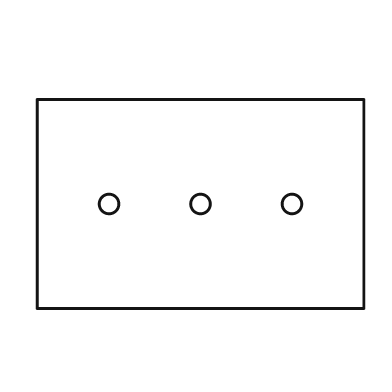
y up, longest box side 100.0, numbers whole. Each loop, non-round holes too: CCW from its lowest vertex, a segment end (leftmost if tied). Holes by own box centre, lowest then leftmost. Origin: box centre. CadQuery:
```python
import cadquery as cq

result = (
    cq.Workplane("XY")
    .moveTo(-50.0, -32.0)
    .lineTo(50.0, -32.0)
    .lineTo(50.0, 32.0)
    .lineTo(-50.0, 32.0)
    .close()
    .moveTo(-28.0, 0.0)
    .circle(3.0)
    .moveTo(0.0, 0.0)
    .circle(3.0)
    .moveTo(28.0, 0.0)
    .circle(3.0)
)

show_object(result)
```